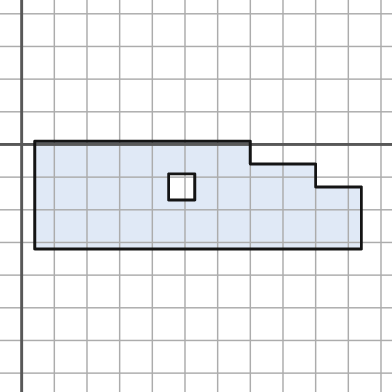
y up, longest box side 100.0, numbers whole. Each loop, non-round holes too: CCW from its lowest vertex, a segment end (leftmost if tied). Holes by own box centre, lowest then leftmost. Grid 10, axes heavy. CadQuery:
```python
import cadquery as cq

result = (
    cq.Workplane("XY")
    .moveTo(4.0, -32.0)
    .lineTo(104.0, -32.0)
    .lineTo(104.0, -13.0)
    .lineTo(90.0, -13.0)
    .lineTo(90.0, -6.0)
    .lineTo(70.0, -6.0)
    .lineTo(70.0, 1.0)
    .lineTo(4.0, 1.0)
    .close()
    .moveTo(45.0, -17.0)
    .lineTo(53.0, -17.0)
    .lineTo(53.0, -9.0)
    .lineTo(45.0, -9.0)
    .close()
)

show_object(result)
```